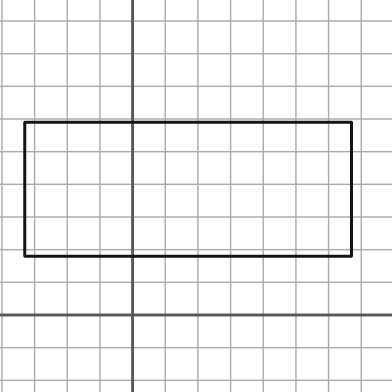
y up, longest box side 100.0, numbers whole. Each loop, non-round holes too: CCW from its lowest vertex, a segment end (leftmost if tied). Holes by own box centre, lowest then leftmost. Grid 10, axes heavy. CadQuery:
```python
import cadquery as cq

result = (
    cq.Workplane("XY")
    .moveTo(-33.0, 18.0)
    .lineTo(67.0, 18.0)
    .lineTo(67.0, 59.0)
    .lineTo(-33.0, 59.0)
    .close()
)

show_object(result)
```